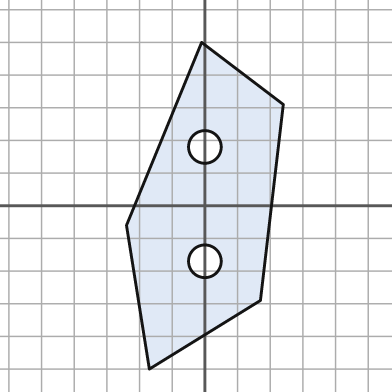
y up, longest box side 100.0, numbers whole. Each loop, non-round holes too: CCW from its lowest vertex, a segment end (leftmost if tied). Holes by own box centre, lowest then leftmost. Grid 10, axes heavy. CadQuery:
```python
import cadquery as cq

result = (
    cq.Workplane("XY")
    .moveTo(-17.0, -50.0)
    .lineTo(17.0, -29.0)
    .lineTo(24.0, 31.0)
    .lineTo(-1.0, 50.0)
    .lineTo(-24.0, -6.0)
    .close()
    .moveTo(0.0, -17.0)
    .circle(5.0)
    .moveTo(0.0, 18.0)
    .circle(5.0)
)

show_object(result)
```